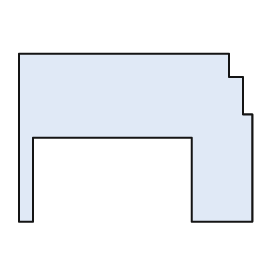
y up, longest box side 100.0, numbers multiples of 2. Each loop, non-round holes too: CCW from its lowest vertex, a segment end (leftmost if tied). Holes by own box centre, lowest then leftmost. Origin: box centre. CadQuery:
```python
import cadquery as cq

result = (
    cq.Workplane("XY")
    .moveTo(-50.0, -36.0)
    .lineTo(-44.0, -36.0)
    .lineTo(-44.0, 0.0)
    .lineTo(24.0, 0.0)
    .lineTo(24.0, -36.0)
    .lineTo(50.0, -36.0)
    .lineTo(50.0, 10.0)
    .lineTo(46.0, 10.0)
    .lineTo(46.0, 26.0)
    .lineTo(40.0, 26.0)
    .lineTo(40.0, 36.0)
    .lineTo(-50.0, 36.0)
    .close()
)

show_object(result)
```